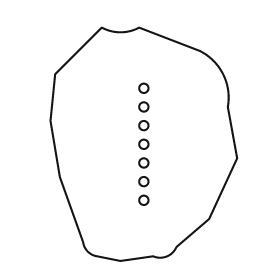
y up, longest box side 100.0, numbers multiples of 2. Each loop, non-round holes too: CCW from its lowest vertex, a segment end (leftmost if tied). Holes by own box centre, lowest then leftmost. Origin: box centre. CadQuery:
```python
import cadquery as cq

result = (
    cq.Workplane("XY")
    .moveTo(-10.0, -50.0)
    .lineTo(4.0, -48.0)
    .threePointArc((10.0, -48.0), (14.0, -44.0))
    .lineTo(28.0, -32.0)
    .lineTo(40.0, -6.0)
    .lineTo(36.0, 16.0)
    .threePointArc((34.0, 30.0), (24.0, 40.0))
    .lineTo(-2.0, 50.0)
    .threePointArc((-10.0, 48.0), (-18.0, 50.0))
    .lineTo(-38.0, 30.0)
    .lineTo(-40.0, 10.0)
    .lineTo(-36.0, -14.0)
    .lineTo(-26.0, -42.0)
    .threePointArc((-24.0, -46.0), (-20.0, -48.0))
    .close()
    .moveTo(0.0, -24.0)
    .circle(2.0)
    .moveTo(0.0, -16.0)
    .circle(2.0)
    .moveTo(0.0, -8.0)
    .circle(2.0)
    .moveTo(0.0, 0.0)
    .circle(2.0)
    .moveTo(0.0, 8.0)
    .circle(2.0)
    .moveTo(0.0, 16.0)
    .circle(2.0)
    .moveTo(0.0, 24.0)
    .circle(2.0)
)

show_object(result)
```